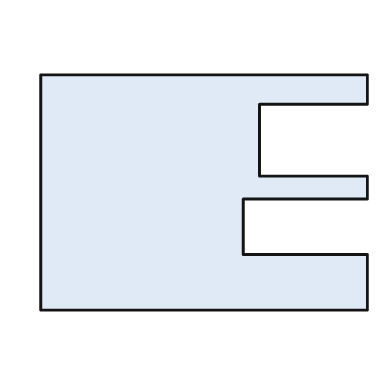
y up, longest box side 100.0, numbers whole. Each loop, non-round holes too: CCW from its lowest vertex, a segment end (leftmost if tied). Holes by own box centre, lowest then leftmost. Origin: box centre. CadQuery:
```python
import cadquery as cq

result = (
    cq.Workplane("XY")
    .moveTo(-50.0, -36.0)
    .lineTo(50.0, -36.0)
    .lineTo(50.0, -19.0)
    .lineTo(12.0, -19.0)
    .lineTo(12.0, -2.0)
    .lineTo(50.0, -2.0)
    .lineTo(50.0, 5.0)
    .lineTo(17.0, 5.0)
    .lineTo(17.0, 27.0)
    .lineTo(50.0, 27.0)
    .lineTo(50.0, 36.0)
    .lineTo(-50.0, 36.0)
    .close()
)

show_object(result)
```